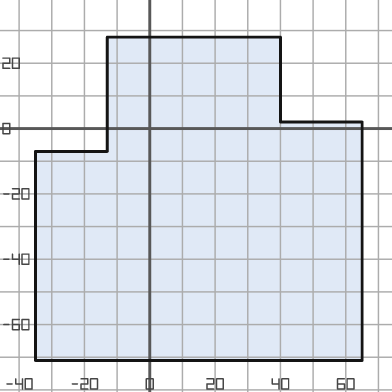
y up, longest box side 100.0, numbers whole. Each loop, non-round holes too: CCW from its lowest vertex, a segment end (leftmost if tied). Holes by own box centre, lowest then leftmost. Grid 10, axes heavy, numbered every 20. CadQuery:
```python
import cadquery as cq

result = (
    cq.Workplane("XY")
    .moveTo(-35.0, -71.0)
    .lineTo(65.0, -71.0)
    .lineTo(65.0, 2.0)
    .lineTo(40.0, 2.0)
    .lineTo(40.0, 28.0)
    .lineTo(-13.0, 28.0)
    .lineTo(-13.0, -7.0)
    .lineTo(-35.0, -7.0)
    .close()
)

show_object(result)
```